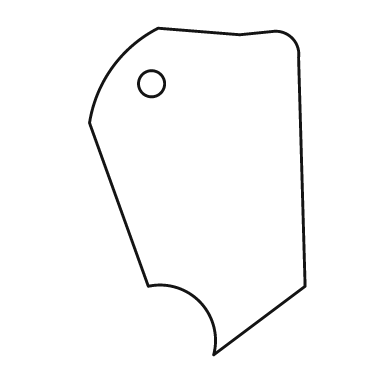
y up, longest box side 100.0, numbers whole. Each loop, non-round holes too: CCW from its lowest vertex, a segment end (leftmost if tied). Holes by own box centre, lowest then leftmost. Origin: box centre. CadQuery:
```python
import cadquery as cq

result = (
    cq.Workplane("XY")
    .moveTo(5.0, -50.0)
    .lineTo(33.0, -29.0)
    .lineTo(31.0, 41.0)
    .threePointArc((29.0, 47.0), (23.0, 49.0))
    .lineTo(13.0, 48.0)
    .lineTo(-12.0, 50.0)
    .threePointArc((-26.0, 38.0), (-33.0, 21.0))
    .lineTo(-15.0, -29.0)
    .threePointArc((1.0, -34.0), (5.0, -50.0))
    .close()
    .moveTo(-14.0, 33.0)
    .circle(4.0)
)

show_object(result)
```